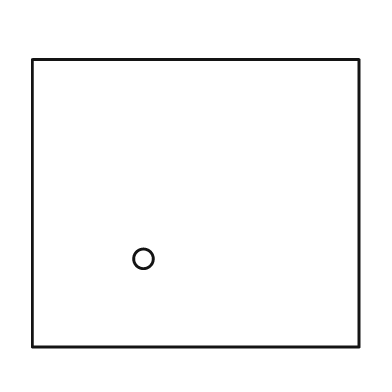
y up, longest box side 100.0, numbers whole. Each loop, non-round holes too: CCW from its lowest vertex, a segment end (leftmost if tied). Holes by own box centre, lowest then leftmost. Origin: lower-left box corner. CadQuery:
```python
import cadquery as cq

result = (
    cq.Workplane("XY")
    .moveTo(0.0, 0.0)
    .lineTo(100.0, 0.0)
    .lineTo(100.0, 88.0)
    .lineTo(0.0, 88.0)
    .close()
    .moveTo(34.0, 27.0)
    .circle(3.0)
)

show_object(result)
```